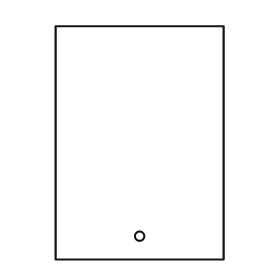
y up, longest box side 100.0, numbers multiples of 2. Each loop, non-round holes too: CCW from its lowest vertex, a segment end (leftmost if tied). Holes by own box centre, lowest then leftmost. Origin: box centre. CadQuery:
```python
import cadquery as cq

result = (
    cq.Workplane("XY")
    .moveTo(-36.0, -50.0)
    .lineTo(36.0, -50.0)
    .lineTo(36.0, 50.0)
    .lineTo(-36.0, 50.0)
    .close()
    .moveTo(0.0, -40.0)
    .circle(2.0)
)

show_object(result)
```